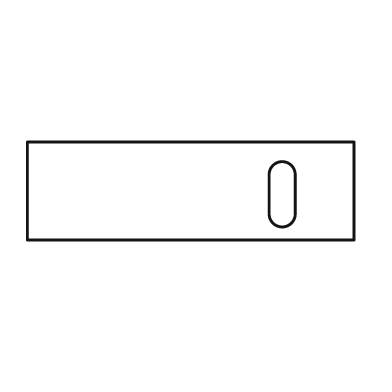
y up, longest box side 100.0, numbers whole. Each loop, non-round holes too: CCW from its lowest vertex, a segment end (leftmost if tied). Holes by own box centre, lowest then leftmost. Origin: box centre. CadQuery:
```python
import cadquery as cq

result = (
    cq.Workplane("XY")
    .moveTo(-50.0, -15.0)
    .lineTo(50.0, -15.0)
    .lineTo(50.0, 15.0)
    .lineTo(-50.0, 15.0)
    .close()
    .moveTo(24.0, -7.0)
    .threePointArc((28.0, -11.0), (32.0, -7.0))
    .lineTo(32.0, 5.0)
    .threePointArc((28.0, 9.0), (24.0, 5.0))
    .close()
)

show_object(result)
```